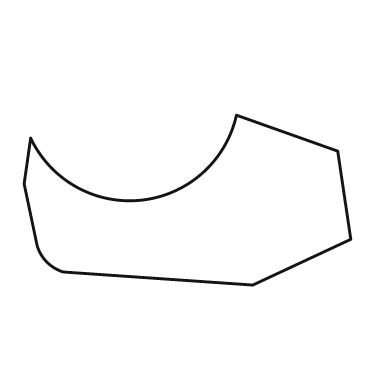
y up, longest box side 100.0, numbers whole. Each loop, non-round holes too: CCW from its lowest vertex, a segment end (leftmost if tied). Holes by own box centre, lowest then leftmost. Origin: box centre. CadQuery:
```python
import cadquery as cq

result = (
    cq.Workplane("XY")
    .moveTo(20.0, -26.0)
    .lineTo(50.0, -12.0)
    .lineTo(46.0, 15.0)
    .lineTo(15.0, 26.0)
    .threePointArc((-14.0, 0.0), (-48.0, 19.0))
    .lineTo(-50.0, 5.0)
    .lineTo(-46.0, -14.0)
    .threePointArc((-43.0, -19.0), (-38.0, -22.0))
    .close()
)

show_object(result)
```